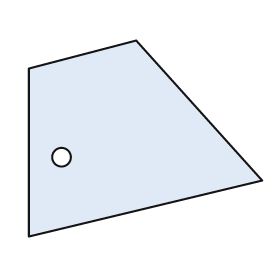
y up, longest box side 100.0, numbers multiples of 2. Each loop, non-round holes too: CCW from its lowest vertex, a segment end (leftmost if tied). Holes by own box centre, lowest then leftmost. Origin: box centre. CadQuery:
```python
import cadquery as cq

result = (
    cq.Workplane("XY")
    .moveTo(-50.0, -42.0)
    .lineTo(50.0, -18.0)
    .lineTo(-4.0, 42.0)
    .lineTo(-50.0, 30.0)
    .close()
    .moveTo(-36.0, -8.0)
    .circle(4.0)
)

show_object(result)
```